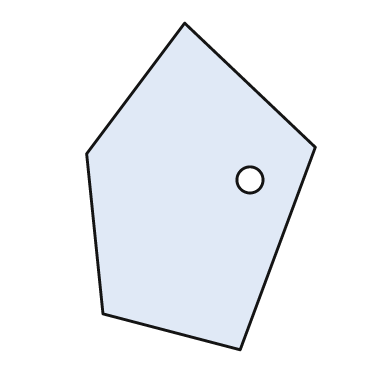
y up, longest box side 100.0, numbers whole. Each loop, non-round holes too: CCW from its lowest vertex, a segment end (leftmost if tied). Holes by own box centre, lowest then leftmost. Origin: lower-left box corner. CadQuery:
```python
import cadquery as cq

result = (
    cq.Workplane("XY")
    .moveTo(47.0, 0.0)
    .lineTo(70.0, 62.0)
    .lineTo(30.0, 100.0)
    .lineTo(0.0, 60.0)
    .lineTo(5.0, 11.0)
    .close()
    .moveTo(50.0, 52.0)
    .circle(4.0)
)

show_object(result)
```